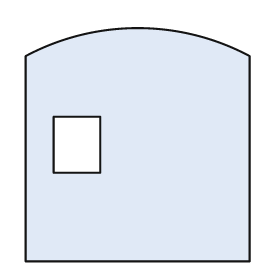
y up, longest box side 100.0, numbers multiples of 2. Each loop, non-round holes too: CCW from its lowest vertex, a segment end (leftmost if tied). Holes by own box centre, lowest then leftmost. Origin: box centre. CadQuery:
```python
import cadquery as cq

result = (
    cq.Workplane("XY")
    .moveTo(-48.0, -50.0)
    .lineTo(48.0, -50.0)
    .lineTo(48.0, 38.0)
    .threePointArc((0.0, 50.0), (-48.0, 38.0))
    .close()
    .moveTo(-36.0, -12.0)
    .lineTo(-16.0, -12.0)
    .lineTo(-16.0, 12.0)
    .lineTo(-36.0, 12.0)
    .close()
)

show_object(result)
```